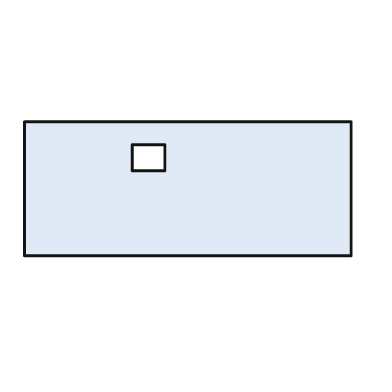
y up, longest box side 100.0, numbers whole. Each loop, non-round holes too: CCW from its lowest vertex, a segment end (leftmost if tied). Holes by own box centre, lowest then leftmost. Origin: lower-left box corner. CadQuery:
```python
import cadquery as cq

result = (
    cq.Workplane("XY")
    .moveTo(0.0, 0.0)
    .lineTo(100.0, 0.0)
    .lineTo(100.0, 41.0)
    .lineTo(0.0, 41.0)
    .close()
    .moveTo(33.0, 26.0)
    .lineTo(43.0, 26.0)
    .lineTo(43.0, 34.0)
    .lineTo(33.0, 34.0)
    .close()
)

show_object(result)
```